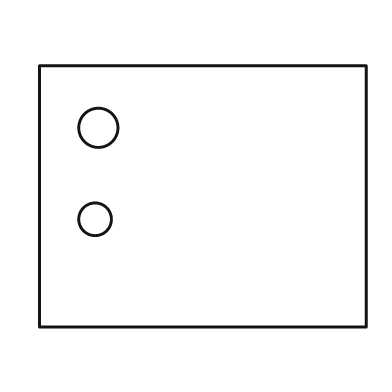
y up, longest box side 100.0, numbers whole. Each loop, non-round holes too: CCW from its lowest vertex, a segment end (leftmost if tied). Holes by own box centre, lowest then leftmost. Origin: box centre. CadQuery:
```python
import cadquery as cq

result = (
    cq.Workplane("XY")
    .moveTo(-50.0, -40.0)
    .lineTo(50.0, -40.0)
    .lineTo(50.0, 40.0)
    .lineTo(-50.0, 40.0)
    .close()
    .moveTo(-33.0, -7.0)
    .circle(5.0)
    .moveTo(-32.0, 21.0)
    .circle(6.0)
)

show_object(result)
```